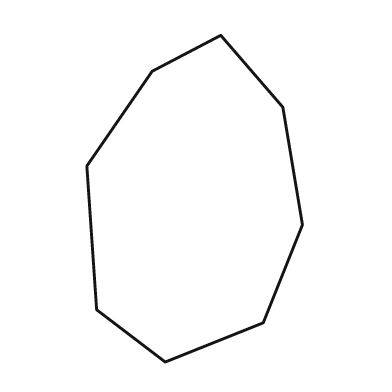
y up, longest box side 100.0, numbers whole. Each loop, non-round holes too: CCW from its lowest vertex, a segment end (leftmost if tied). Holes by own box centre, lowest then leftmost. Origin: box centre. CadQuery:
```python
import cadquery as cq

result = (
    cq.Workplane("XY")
    .moveTo(-9.0, -50.0)
    .lineTo(21.0, -38.0)
    .lineTo(33.0, -8.0)
    .lineTo(27.0, 28.0)
    .lineTo(8.0, 50.0)
    .lineTo(-13.0, 39.0)
    .lineTo(-33.0, 10.0)
    .lineTo(-30.0, -34.0)
    .close()
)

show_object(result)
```